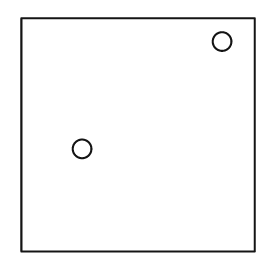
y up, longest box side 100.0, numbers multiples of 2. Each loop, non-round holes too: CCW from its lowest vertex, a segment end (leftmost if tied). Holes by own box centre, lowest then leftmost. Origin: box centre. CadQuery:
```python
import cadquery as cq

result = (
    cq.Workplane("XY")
    .moveTo(-50.0, -50.0)
    .lineTo(50.0, -50.0)
    .lineTo(50.0, 50.0)
    .lineTo(-50.0, 50.0)
    .close()
    .moveTo(-24.0, -6.0)
    .circle(4.0)
    .moveTo(36.0, 40.0)
    .circle(4.0)
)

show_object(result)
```